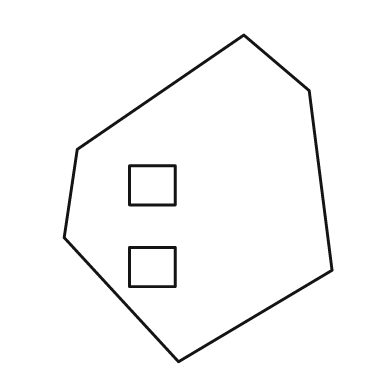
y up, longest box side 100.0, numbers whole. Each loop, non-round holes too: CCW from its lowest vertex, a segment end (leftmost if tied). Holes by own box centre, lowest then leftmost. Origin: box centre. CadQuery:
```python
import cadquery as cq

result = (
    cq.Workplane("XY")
    .moveTo(-6.0, -50.0)
    .lineTo(41.0, -22.0)
    .lineTo(34.0, 33.0)
    .lineTo(14.0, 50.0)
    .lineTo(-37.0, 15.0)
    .lineTo(-41.0, -12.0)
    .close()
    .moveTo(-21.0, -27.0)
    .lineTo(-7.0, -27.0)
    .lineTo(-7.0, -15.0)
    .lineTo(-21.0, -15.0)
    .close()
    .moveTo(-21.0, -2.0)
    .lineTo(-7.0, -2.0)
    .lineTo(-7.0, 10.0)
    .lineTo(-21.0, 10.0)
    .close()
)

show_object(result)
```